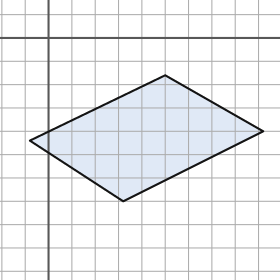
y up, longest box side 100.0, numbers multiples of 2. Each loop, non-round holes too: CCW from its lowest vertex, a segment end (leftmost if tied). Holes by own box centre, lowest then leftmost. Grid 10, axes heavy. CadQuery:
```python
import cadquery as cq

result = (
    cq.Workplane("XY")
    .moveTo(32.0, -70.0)
    .lineTo(92.0, -40.0)
    .lineTo(50.0, -16.0)
    .lineTo(-8.0, -44.0)
    .close()
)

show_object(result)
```